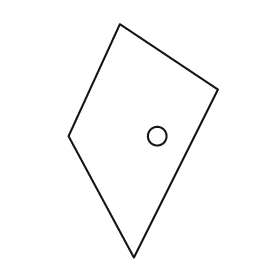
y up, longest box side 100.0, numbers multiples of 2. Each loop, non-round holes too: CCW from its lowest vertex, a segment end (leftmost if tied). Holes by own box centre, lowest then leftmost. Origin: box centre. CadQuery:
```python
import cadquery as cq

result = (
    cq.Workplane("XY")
    .moveTo(-4.0, -50.0)
    .lineTo(32.0, 22.0)
    .lineTo(-10.0, 50.0)
    .lineTo(-32.0, 2.0)
    .close()
    .moveTo(6.0, 2.0)
    .circle(4.0)
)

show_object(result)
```